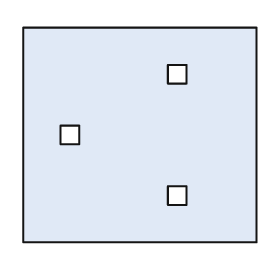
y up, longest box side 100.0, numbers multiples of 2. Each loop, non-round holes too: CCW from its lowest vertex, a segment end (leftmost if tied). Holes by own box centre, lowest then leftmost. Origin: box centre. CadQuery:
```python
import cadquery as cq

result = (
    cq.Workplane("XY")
    .moveTo(-50.0, -46.0)
    .lineTo(50.0, -46.0)
    .lineTo(50.0, 46.0)
    .lineTo(-50.0, 46.0)
    .close()
    .moveTo(12.0, -30.0)
    .lineTo(20.0, -30.0)
    .lineTo(20.0, -22.0)
    .lineTo(12.0, -22.0)
    .close()
    .moveTo(-34.0, -4.0)
    .lineTo(-26.0, -4.0)
    .lineTo(-26.0, 4.0)
    .lineTo(-34.0, 4.0)
    .close()
    .moveTo(12.0, 22.0)
    .lineTo(20.0, 22.0)
    .lineTo(20.0, 30.0)
    .lineTo(12.0, 30.0)
    .close()
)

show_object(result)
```